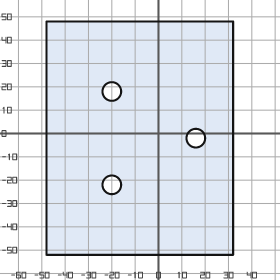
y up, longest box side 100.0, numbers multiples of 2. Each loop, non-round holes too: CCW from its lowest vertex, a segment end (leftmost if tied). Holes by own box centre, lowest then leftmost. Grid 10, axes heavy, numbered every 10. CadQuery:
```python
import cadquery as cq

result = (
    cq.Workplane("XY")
    .moveTo(-48.0, -52.0)
    .lineTo(32.0, -52.0)
    .lineTo(32.0, 48.0)
    .lineTo(-48.0, 48.0)
    .close()
    .moveTo(-20.0, -22.0)
    .circle(4.0)
    .moveTo(16.0, -2.0)
    .circle(4.0)
    .moveTo(-20.0, 18.0)
    .circle(4.0)
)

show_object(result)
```